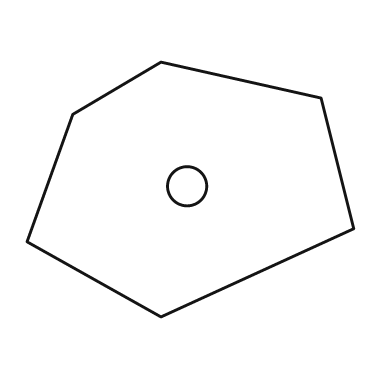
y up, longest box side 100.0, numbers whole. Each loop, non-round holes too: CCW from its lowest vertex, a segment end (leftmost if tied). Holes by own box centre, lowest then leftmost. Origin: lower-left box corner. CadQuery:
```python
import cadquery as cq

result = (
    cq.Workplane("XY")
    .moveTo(41.0, 0.0)
    .lineTo(100.0, 27.0)
    .lineTo(90.0, 67.0)
    .lineTo(41.0, 78.0)
    .lineTo(14.0, 62.0)
    .lineTo(0.0, 23.0)
    .close()
    .moveTo(49.0, 40.0)
    .circle(6.0)
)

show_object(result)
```